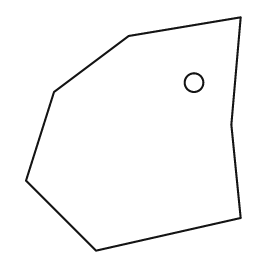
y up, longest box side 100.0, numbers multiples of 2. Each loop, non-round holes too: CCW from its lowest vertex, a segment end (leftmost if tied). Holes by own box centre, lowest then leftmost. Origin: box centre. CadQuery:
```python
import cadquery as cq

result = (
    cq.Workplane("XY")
    .moveTo(-16.0, -50.0)
    .lineTo(46.0, -36.0)
    .lineTo(42.0, 4.0)
    .lineTo(46.0, 50.0)
    .lineTo(-2.0, 42.0)
    .lineTo(-34.0, 18.0)
    .lineTo(-46.0, -20.0)
    .close()
    .moveTo(26.0, 22.0)
    .circle(4.0)
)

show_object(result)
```